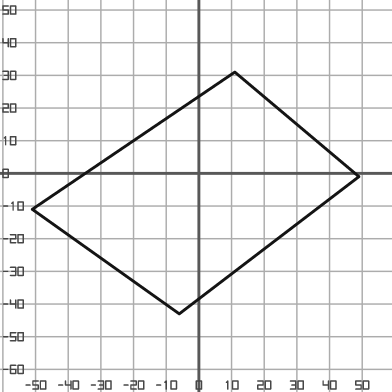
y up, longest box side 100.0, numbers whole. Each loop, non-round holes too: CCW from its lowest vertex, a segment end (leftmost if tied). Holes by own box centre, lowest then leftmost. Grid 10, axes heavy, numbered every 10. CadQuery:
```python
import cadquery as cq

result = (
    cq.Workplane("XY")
    .moveTo(-6.0, -43.0)
    .lineTo(49.0, -1.0)
    .lineTo(11.0, 31.0)
    .lineTo(-51.0, -11.0)
    .close()
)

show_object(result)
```